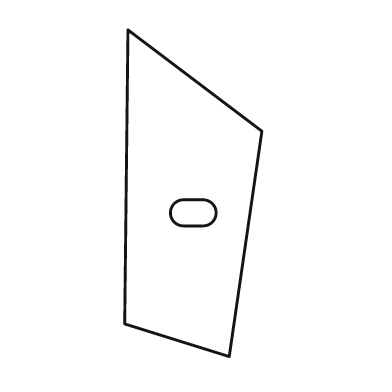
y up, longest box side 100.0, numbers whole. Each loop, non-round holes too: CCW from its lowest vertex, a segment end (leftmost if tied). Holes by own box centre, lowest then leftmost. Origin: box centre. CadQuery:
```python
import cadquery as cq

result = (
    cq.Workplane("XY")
    .moveTo(11.0, -50.0)
    .lineTo(21.0, 19.0)
    .lineTo(-20.0, 50.0)
    .lineTo(-21.0, -40.0)
    .close()
    .moveTo(-3.0, -10.0)
    .lineTo(3.0, -10.0)
    .threePointArc((7.0, -6.0), (3.0, -2.0))
    .lineTo(-3.0, -2.0)
    .threePointArc((-7.0, -6.0), (-3.0, -10.0))
    .close()
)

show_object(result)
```